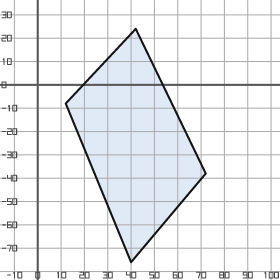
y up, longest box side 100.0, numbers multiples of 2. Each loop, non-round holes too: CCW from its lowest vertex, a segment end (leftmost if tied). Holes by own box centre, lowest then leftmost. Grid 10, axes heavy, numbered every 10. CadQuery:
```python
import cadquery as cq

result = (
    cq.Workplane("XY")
    .moveTo(40.0, -76.0)
    .lineTo(72.0, -38.0)
    .lineTo(42.0, 24.0)
    .lineTo(12.0, -8.0)
    .close()
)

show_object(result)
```